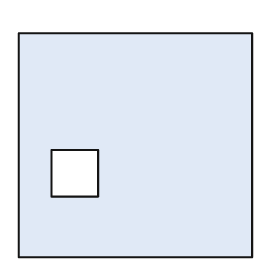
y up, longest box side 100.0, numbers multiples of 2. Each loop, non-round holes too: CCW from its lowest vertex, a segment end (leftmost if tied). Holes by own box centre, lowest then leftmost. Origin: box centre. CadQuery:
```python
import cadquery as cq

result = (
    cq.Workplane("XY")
    .moveTo(-50.0, -48.0)
    .lineTo(50.0, -48.0)
    .lineTo(50.0, 48.0)
    .lineTo(-50.0, 48.0)
    .close()
    .moveTo(-36.0, -22.0)
    .lineTo(-16.0, -22.0)
    .lineTo(-16.0, -2.0)
    .lineTo(-36.0, -2.0)
    .close()
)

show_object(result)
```